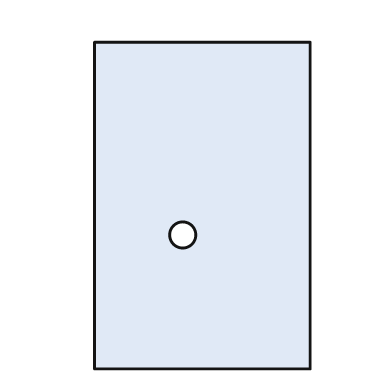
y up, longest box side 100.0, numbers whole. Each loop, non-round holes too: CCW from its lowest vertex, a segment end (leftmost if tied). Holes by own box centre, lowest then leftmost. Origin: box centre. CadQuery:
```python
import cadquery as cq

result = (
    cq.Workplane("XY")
    .moveTo(-33.0, -50.0)
    .lineTo(33.0, -50.0)
    .lineTo(33.0, 50.0)
    .lineTo(-33.0, 50.0)
    .close()
    .moveTo(-6.0, -9.0)
    .circle(4.0)
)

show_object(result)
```